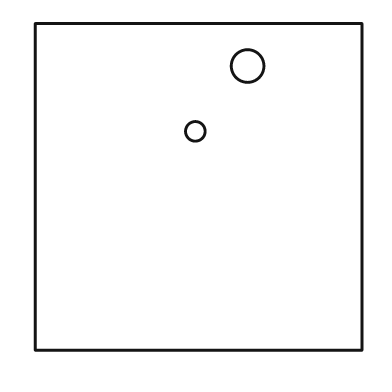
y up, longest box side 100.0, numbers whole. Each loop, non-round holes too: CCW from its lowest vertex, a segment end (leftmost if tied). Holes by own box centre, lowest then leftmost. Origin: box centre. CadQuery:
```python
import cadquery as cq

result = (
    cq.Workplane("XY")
    .moveTo(-50.0, -50.0)
    .lineTo(50.0, -50.0)
    .lineTo(50.0, 50.0)
    .lineTo(-50.0, 50.0)
    .close()
    .moveTo(-1.0, 17.0)
    .circle(3.0)
    .moveTo(15.0, 37.0)
    .circle(5.0)
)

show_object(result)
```